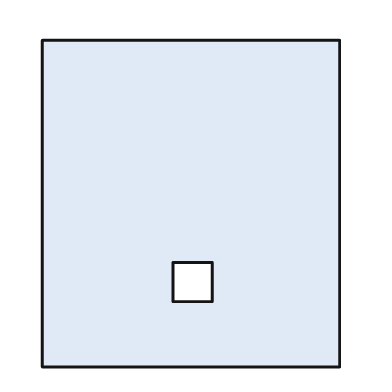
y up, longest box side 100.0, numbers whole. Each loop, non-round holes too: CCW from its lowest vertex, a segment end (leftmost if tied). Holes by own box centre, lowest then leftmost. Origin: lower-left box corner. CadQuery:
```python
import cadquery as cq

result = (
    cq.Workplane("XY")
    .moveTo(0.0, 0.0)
    .lineTo(91.0, 0.0)
    .lineTo(91.0, 100.0)
    .lineTo(0.0, 100.0)
    .close()
    .moveTo(40.0, 20.0)
    .lineTo(52.0, 20.0)
    .lineTo(52.0, 32.0)
    .lineTo(40.0, 32.0)
    .close()
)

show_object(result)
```